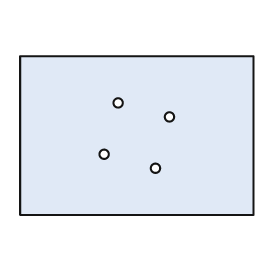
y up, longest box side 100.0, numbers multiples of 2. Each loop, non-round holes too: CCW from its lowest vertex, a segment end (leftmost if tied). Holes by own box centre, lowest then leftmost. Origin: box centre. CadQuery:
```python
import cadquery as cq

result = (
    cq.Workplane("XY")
    .moveTo(-50.0, -34.0)
    .lineTo(50.0, -34.0)
    .lineTo(50.0, 34.0)
    .lineTo(-50.0, 34.0)
    .close()
    .moveTo(8.0, -14.0)
    .circle(2.0)
    .moveTo(-14.0, -8.0)
    .circle(2.0)
    .moveTo(14.0, 8.0)
    .circle(2.0)
    .moveTo(-8.0, 14.0)
    .circle(2.0)
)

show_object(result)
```